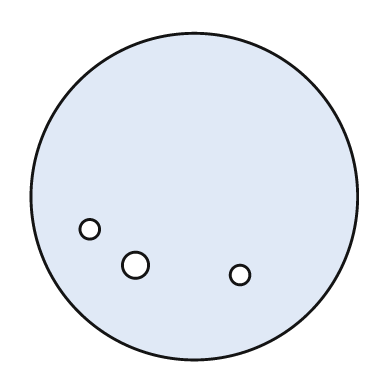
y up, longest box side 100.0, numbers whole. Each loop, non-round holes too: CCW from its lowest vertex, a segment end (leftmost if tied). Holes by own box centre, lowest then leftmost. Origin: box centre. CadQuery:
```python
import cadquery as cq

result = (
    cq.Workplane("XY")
    .moveTo(0.0, 0.0)
    .circle(50.0)
    .moveTo(14.0, -24.0)
    .circle(3.0)
    .moveTo(-18.0, -21.0)
    .circle(4.0)
    .moveTo(-32.0, -10.0)
    .circle(3.0)
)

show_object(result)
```